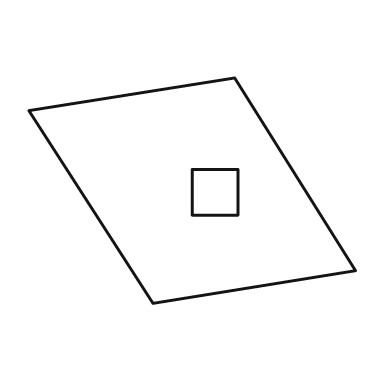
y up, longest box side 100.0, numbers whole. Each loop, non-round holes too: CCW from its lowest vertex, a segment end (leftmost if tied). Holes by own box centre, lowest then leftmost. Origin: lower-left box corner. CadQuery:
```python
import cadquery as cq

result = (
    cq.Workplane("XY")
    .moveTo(38.0, 0.0)
    .lineTo(100.0, 10.0)
    .lineTo(63.0, 69.0)
    .lineTo(0.0, 59.0)
    .close()
    .moveTo(50.0, 27.0)
    .lineTo(64.0, 27.0)
    .lineTo(64.0, 41.0)
    .lineTo(50.0, 41.0)
    .close()
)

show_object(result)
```